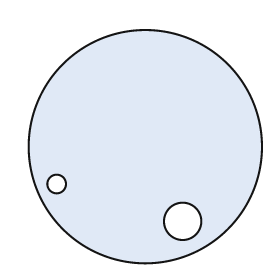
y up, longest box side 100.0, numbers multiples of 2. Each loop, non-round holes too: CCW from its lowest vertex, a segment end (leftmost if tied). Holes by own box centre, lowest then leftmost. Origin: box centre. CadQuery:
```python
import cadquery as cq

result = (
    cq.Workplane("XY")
    .moveTo(0.0, 0.0)
    .circle(50.0)
    .moveTo(16.0, -32.0)
    .circle(8.0)
    .moveTo(-38.0, -16.0)
    .circle(4.0)
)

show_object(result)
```